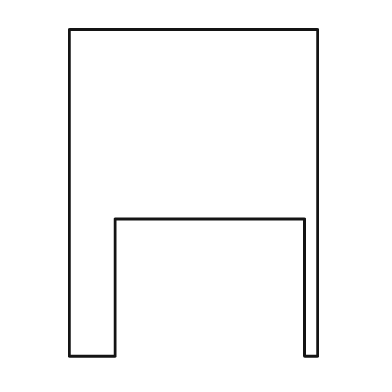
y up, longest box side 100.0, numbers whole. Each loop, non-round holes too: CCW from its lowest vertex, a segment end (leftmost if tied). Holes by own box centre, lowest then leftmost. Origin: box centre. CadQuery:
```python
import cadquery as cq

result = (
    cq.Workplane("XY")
    .moveTo(-38.0, -50.0)
    .lineTo(-24.0, -50.0)
    .lineTo(-24.0, -8.0)
    .lineTo(34.0, -8.0)
    .lineTo(34.0, -50.0)
    .lineTo(38.0, -50.0)
    .lineTo(38.0, 50.0)
    .lineTo(-38.0, 50.0)
    .close()
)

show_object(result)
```